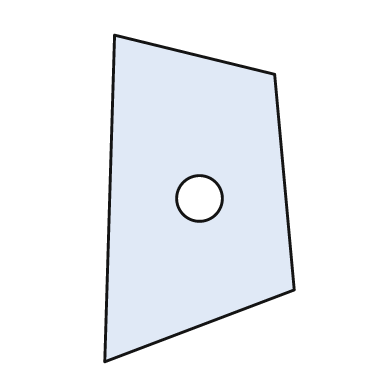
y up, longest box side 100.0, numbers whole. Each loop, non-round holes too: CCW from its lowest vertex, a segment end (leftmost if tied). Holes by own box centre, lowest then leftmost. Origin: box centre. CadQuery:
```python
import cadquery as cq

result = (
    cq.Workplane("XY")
    .moveTo(-29.0, -50.0)
    .lineTo(29.0, -28.0)
    .lineTo(23.0, 38.0)
    .lineTo(-26.0, 50.0)
    .close()
    .moveTo(0.0, 0.0)
    .circle(7.0)
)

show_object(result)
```